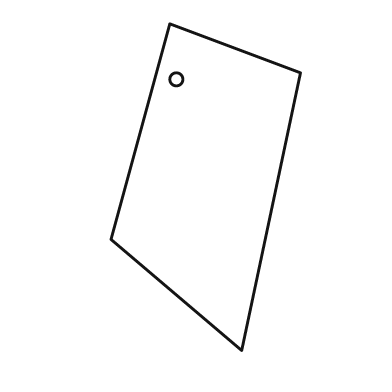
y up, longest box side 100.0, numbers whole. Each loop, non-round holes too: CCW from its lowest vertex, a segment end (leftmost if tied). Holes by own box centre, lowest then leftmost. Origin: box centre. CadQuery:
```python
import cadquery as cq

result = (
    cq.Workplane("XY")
    .moveTo(11.0, -50.0)
    .lineTo(29.0, 35.0)
    .lineTo(-11.0, 50.0)
    .lineTo(-29.0, -16.0)
    .close()
    .moveTo(-9.0, 33.0)
    .circle(2.0)
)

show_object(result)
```